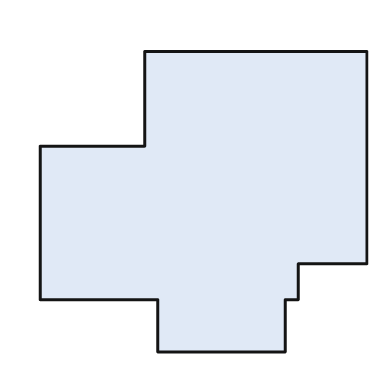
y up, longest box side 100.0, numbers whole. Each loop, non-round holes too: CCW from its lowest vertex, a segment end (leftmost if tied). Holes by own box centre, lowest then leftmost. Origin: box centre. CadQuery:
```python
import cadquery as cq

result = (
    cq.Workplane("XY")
    .moveTo(-14.0, -46.0)
    .lineTo(25.0, -46.0)
    .lineTo(25.0, -30.0)
    .lineTo(29.0, -30.0)
    .lineTo(29.0, -19.0)
    .lineTo(50.0, -19.0)
    .lineTo(50.0, 46.0)
    .lineTo(-18.0, 46.0)
    .lineTo(-18.0, 17.0)
    .lineTo(-50.0, 17.0)
    .lineTo(-50.0, -30.0)
    .lineTo(-14.0, -30.0)
    .close()
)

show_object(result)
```